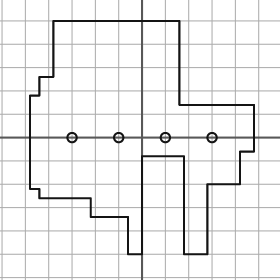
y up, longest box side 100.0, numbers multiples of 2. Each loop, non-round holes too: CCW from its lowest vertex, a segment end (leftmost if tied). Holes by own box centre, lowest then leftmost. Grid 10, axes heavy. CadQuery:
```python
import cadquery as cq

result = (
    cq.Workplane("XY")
    .moveTo(-6.0, -50.0)
    .lineTo(0.0, -50.0)
    .lineTo(0.0, -8.0)
    .lineTo(18.0, -8.0)
    .lineTo(18.0, -50.0)
    .lineTo(28.0, -50.0)
    .lineTo(28.0, -20.0)
    .lineTo(42.0, -20.0)
    .lineTo(42.0, -6.0)
    .lineTo(48.0, -6.0)
    .lineTo(48.0, 14.0)
    .lineTo(16.0, 14.0)
    .lineTo(16.0, 50.0)
    .lineTo(-38.0, 50.0)
    .lineTo(-38.0, 26.0)
    .lineTo(-44.0, 26.0)
    .lineTo(-44.0, 18.0)
    .lineTo(-48.0, 18.0)
    .lineTo(-48.0, -22.0)
    .lineTo(-44.0, -22.0)
    .lineTo(-44.0, -26.0)
    .lineTo(-22.0, -26.0)
    .lineTo(-22.0, -34.0)
    .lineTo(-6.0, -34.0)
    .close()
    .moveTo(-30.0, 0.0)
    .circle(2.0)
    .moveTo(-10.0, 0.0)
    .circle(2.0)
    .moveTo(10.0, 0.0)
    .circle(2.0)
    .moveTo(30.0, 0.0)
    .circle(2.0)
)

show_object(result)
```